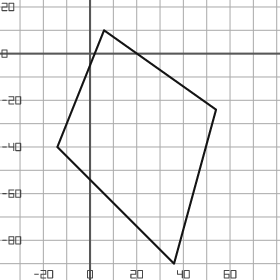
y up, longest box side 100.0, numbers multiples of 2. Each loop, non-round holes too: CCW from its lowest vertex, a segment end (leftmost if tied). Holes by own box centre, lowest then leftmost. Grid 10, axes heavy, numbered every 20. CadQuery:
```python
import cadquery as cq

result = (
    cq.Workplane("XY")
    .moveTo(36.0, -90.0)
    .lineTo(54.0, -24.0)
    .lineTo(6.0, 10.0)
    .lineTo(-14.0, -40.0)
    .close()
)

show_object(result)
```